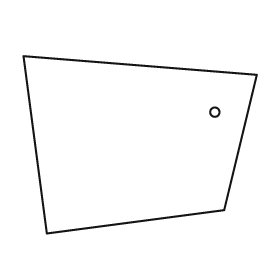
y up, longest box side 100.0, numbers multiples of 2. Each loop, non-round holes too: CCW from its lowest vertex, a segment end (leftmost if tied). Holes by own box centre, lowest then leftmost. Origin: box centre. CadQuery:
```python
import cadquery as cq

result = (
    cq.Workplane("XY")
    .moveTo(-40.0, -38.0)
    .lineTo(36.0, -28.0)
    .lineTo(50.0, 30.0)
    .lineTo(-50.0, 38.0)
    .close()
    .moveTo(32.0, 14.0)
    .circle(2.0)
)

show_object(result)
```